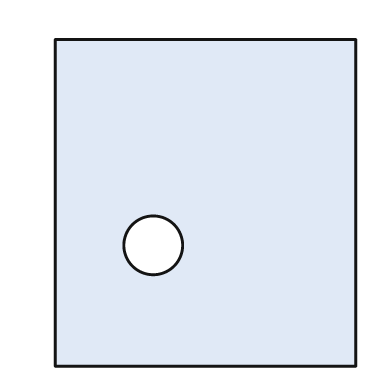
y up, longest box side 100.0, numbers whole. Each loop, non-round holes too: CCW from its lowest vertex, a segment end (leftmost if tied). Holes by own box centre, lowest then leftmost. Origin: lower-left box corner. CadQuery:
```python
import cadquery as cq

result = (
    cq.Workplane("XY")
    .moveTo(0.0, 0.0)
    .lineTo(92.0, 0.0)
    .lineTo(92.0, 100.0)
    .lineTo(0.0, 100.0)
    .close()
    .moveTo(30.0, 37.0)
    .circle(9.0)
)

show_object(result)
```